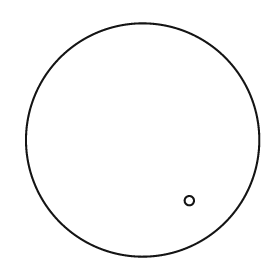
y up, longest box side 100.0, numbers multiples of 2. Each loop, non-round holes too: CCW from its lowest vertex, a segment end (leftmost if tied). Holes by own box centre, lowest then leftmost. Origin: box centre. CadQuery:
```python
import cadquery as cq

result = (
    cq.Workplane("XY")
    .moveTo(0.0, 0.0)
    .circle(50.0)
    .moveTo(20.0, -26.0)
    .circle(2.0)
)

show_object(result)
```